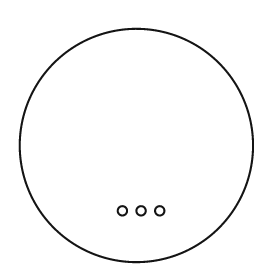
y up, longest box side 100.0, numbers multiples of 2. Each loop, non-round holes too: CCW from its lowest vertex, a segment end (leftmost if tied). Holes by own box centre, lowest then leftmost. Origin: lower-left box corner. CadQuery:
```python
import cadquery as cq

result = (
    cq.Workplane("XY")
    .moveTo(50.0, 50.0)
    .circle(50.0)
    .moveTo(44.0, 22.0)
    .circle(2.0)
    .moveTo(52.0, 22.0)
    .circle(2.0)
    .moveTo(60.0, 22.0)
    .circle(2.0)
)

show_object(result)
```